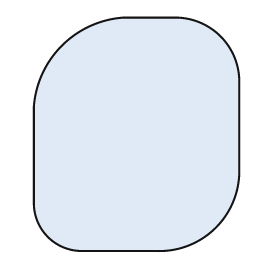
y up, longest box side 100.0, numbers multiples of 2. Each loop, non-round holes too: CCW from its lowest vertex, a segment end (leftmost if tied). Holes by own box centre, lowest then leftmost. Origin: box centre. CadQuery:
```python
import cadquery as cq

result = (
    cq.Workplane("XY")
    .moveTo(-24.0, -50.0)
    .lineTo(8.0, -50.0)
    .threePointArc((34.0, -40.0), (44.0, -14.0))
    .lineTo(44.0, 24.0)
    .threePointArc((36.0, 42.0), (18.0, 50.0))
    .lineTo(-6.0, 50.0)
    .threePointArc((-32.0, 38.0), (-44.0, 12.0))
    .lineTo(-44.0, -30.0)
    .threePointArc((-38.0, -44.0), (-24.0, -50.0))
    .close()
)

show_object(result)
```